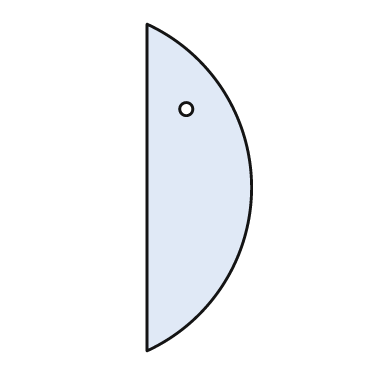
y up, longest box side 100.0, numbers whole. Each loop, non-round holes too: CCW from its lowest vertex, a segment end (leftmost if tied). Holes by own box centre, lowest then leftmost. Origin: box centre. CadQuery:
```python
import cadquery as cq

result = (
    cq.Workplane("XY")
    .moveTo(-16.0, -50.0)
    .threePointArc((16.0, 0.0), (-16.0, 50.0))
    .close()
    .moveTo(-4.0, 24.0)
    .circle(2.0)
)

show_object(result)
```